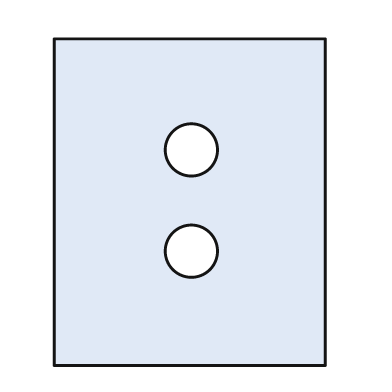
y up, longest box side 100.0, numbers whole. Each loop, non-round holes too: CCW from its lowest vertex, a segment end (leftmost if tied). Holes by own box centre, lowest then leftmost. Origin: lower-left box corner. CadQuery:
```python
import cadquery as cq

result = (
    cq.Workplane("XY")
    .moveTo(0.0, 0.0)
    .lineTo(83.0, 0.0)
    .lineTo(83.0, 100.0)
    .lineTo(0.0, 100.0)
    .close()
    .moveTo(42.0, 35.0)
    .circle(8.0)
    .moveTo(42.0, 66.0)
    .circle(8.0)
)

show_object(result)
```